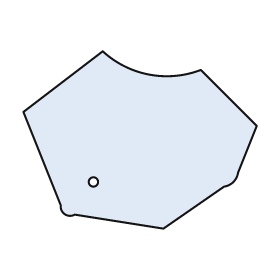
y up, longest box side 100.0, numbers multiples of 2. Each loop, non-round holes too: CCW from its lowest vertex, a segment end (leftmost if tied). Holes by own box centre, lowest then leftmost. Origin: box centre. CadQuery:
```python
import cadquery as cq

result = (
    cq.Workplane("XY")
    .moveTo(10.0, -38.0)
    .lineTo(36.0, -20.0)
    .threePointArc((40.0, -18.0), (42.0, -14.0))
    .lineTo(50.0, 6.0)
    .lineTo(26.0, 30.0)
    .threePointArc((4.0, 28.0), (-16.0, 38.0))
    .lineTo(-50.0, 12.0)
    .lineTo(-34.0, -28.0)
    .threePointArc((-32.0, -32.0), (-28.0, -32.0))
    .close()
    .moveTo(-20.0, -18.0)
    .circle(2.0)
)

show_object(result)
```